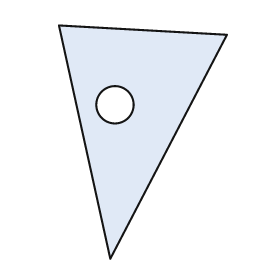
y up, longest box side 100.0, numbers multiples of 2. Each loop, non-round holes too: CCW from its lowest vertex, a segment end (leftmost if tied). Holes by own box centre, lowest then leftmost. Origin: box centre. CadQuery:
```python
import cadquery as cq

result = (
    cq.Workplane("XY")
    .moveTo(-14.0, -50.0)
    .lineTo(36.0, 46.0)
    .lineTo(-36.0, 50.0)
    .close()
    .moveTo(-12.0, 16.0)
    .circle(8.0)
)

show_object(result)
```